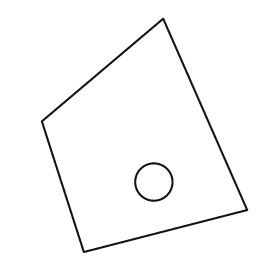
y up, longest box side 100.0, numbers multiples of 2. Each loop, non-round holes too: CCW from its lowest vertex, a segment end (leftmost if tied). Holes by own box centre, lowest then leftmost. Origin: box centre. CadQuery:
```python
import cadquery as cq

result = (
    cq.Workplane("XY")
    .moveTo(-26.0, -50.0)
    .lineTo(44.0, -32.0)
    .lineTo(8.0, 50.0)
    .lineTo(-44.0, 6.0)
    .close()
    .moveTo(4.0, -20.0)
    .circle(8.0)
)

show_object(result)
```